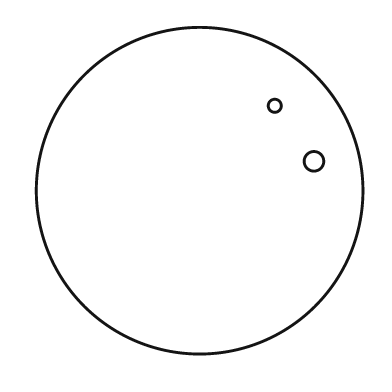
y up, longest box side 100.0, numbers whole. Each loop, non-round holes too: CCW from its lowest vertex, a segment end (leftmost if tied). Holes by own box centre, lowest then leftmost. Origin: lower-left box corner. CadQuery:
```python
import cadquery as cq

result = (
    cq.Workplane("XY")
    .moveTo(50.0, 50.0)
    .circle(50.0)
    .moveTo(85.0, 59.0)
    .circle(3.0)
    .moveTo(73.0, 76.0)
    .circle(2.0)
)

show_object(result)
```